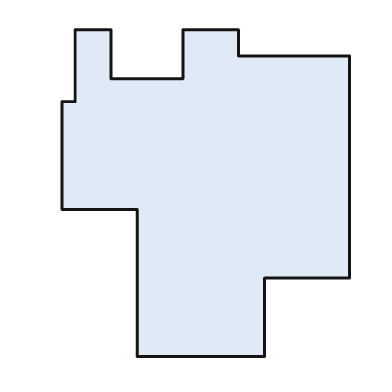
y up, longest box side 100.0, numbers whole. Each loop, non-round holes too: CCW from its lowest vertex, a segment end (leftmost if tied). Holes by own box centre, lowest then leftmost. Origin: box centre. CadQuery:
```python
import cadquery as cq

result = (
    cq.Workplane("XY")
    .moveTo(-21.0, -50.0)
    .lineTo(18.0, -50.0)
    .lineTo(18.0, -26.0)
    .lineTo(44.0, -26.0)
    .lineTo(44.0, 42.0)
    .lineTo(10.0, 42.0)
    .lineTo(10.0, 50.0)
    .lineTo(-7.0, 50.0)
    .lineTo(-7.0, 35.0)
    .lineTo(-29.0, 35.0)
    .lineTo(-29.0, 50.0)
    .lineTo(-40.0, 50.0)
    .lineTo(-40.0, 28.0)
    .lineTo(-44.0, 28.0)
    .lineTo(-44.0, -5.0)
    .lineTo(-21.0, -5.0)
    .close()
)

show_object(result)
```